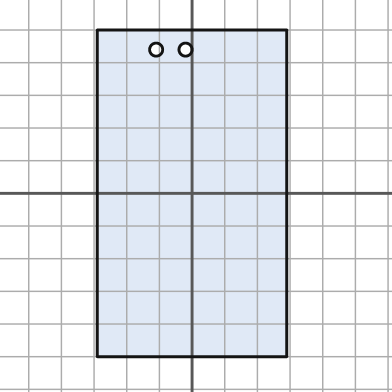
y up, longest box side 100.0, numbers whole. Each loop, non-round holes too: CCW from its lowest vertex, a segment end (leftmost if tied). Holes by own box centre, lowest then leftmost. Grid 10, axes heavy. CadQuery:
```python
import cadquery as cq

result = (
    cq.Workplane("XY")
    .moveTo(-29.0, -50.0)
    .lineTo(29.0, -50.0)
    .lineTo(29.0, 50.0)
    .lineTo(-29.0, 50.0)
    .close()
    .moveTo(-11.0, 44.0)
    .circle(2.0)
    .moveTo(-2.0, 44.0)
    .circle(2.0)
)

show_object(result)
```